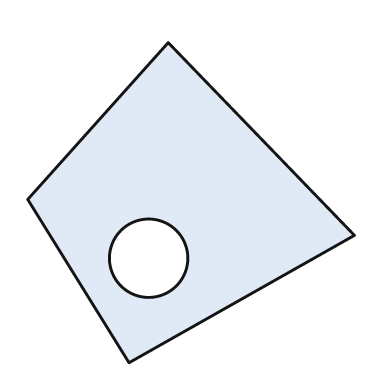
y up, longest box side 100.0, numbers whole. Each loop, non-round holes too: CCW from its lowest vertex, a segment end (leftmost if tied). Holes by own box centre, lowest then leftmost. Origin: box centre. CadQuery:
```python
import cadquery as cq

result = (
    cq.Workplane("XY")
    .moveTo(-19.0, -49.0)
    .lineTo(50.0, -10.0)
    .lineTo(-7.0, 49.0)
    .lineTo(-50.0, 1.0)
    .close()
    .moveTo(-13.0, -17.0)
    .circle(12.0)
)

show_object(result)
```